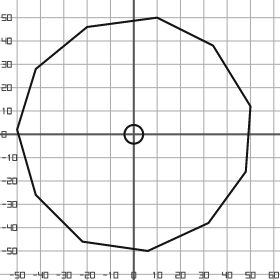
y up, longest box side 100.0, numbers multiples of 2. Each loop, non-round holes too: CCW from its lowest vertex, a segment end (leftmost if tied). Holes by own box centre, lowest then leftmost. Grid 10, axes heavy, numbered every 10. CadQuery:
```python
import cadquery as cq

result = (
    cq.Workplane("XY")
    .moveTo(6.0, -50.0)
    .lineTo(32.0, -38.0)
    .lineTo(48.0, -16.0)
    .lineTo(50.0, 12.0)
    .lineTo(34.0, 38.0)
    .lineTo(10.0, 50.0)
    .lineTo(-20.0, 46.0)
    .lineTo(-42.0, 28.0)
    .lineTo(-50.0, 2.0)
    .lineTo(-42.0, -26.0)
    .lineTo(-22.0, -46.0)
    .close()
    .moveTo(0.0, 0.0)
    .circle(4.0)
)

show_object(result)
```